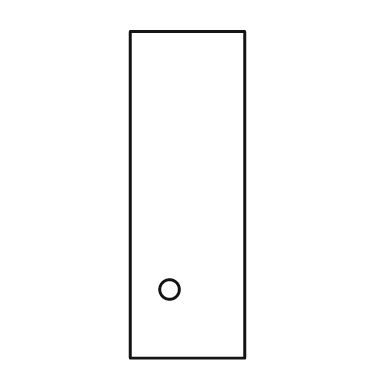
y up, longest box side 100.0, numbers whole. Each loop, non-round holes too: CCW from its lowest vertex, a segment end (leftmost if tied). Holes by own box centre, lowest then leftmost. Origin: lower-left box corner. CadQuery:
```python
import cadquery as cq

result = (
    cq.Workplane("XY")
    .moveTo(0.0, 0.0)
    .lineTo(35.0, 0.0)
    .lineTo(35.0, 100.0)
    .lineTo(0.0, 100.0)
    .close()
    .moveTo(12.0, 21.0)
    .circle(3.0)
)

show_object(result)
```